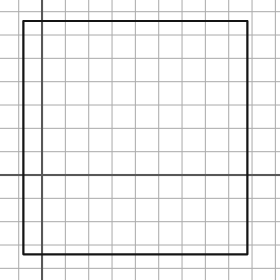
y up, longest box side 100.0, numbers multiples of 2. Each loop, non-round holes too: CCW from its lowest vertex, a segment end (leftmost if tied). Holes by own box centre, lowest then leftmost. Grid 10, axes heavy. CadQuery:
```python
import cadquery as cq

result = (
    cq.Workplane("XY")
    .moveTo(-8.0, -34.0)
    .lineTo(88.0, -34.0)
    .lineTo(88.0, 66.0)
    .lineTo(-8.0, 66.0)
    .close()
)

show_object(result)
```